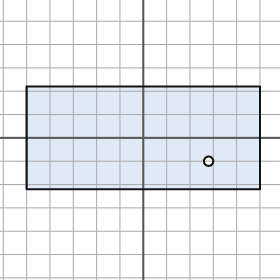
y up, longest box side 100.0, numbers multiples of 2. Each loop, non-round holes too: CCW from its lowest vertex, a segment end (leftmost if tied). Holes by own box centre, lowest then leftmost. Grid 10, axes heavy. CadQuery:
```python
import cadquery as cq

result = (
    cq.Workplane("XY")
    .moveTo(-50.0, -22.0)
    .lineTo(50.0, -22.0)
    .lineTo(50.0, 22.0)
    .lineTo(-50.0, 22.0)
    .close()
    .moveTo(28.0, -10.0)
    .circle(2.0)
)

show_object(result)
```